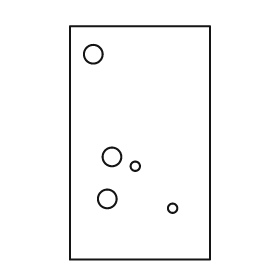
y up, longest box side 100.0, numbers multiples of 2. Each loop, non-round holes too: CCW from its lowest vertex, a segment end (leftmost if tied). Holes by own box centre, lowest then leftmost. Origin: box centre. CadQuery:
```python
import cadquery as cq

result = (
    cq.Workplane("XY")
    .moveTo(-30.0, -50.0)
    .lineTo(30.0, -50.0)
    .lineTo(30.0, 50.0)
    .lineTo(-30.0, 50.0)
    .close()
    .moveTo(14.0, -28.0)
    .circle(2.0)
    .moveTo(-14.0, -24.0)
    .circle(4.0)
    .moveTo(-2.0, -10.0)
    .circle(2.0)
    .moveTo(-12.0, -6.0)
    .circle(4.0)
    .moveTo(-20.0, 38.0)
    .circle(4.0)
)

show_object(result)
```